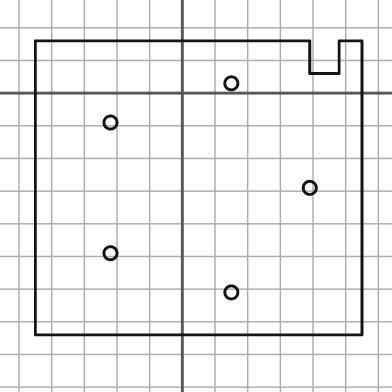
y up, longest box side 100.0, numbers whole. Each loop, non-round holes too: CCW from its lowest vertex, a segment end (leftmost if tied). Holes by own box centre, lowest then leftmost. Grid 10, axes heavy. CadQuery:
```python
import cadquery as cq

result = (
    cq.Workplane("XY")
    .moveTo(-45.0, -74.0)
    .lineTo(55.0, -74.0)
    .lineTo(55.0, 16.0)
    .lineTo(48.0, 16.0)
    .lineTo(48.0, 6.0)
    .lineTo(39.0, 6.0)
    .lineTo(39.0, 16.0)
    .lineTo(-45.0, 16.0)
    .close()
    .moveTo(15.0, -61.0)
    .circle(2.0)
    .moveTo(-22.0, -49.0)
    .circle(2.0)
    .moveTo(39.0, -29.0)
    .circle(2.0)
    .moveTo(-22.0, -9.0)
    .circle(2.0)
    .moveTo(15.0, 3.0)
    .circle(2.0)
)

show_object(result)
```